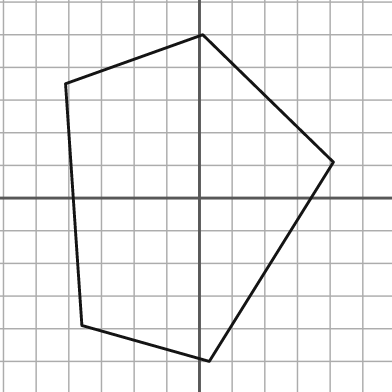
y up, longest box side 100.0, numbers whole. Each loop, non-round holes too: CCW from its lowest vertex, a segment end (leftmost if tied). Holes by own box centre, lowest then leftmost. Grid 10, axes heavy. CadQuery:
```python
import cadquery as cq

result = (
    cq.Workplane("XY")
    .moveTo(3.0, -50.0)
    .lineTo(41.0, 11.0)
    .lineTo(1.0, 50.0)
    .lineTo(-41.0, 35.0)
    .lineTo(-36.0, -39.0)
    .close()
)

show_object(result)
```